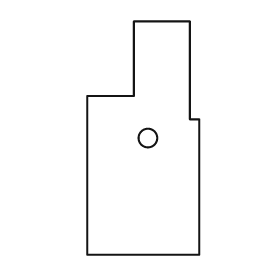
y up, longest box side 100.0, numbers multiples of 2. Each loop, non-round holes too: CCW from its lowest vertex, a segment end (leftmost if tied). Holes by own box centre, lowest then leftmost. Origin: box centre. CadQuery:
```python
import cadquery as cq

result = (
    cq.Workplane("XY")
    .moveTo(-24.0, -50.0)
    .lineTo(24.0, -50.0)
    .lineTo(24.0, 8.0)
    .lineTo(20.0, 8.0)
    .lineTo(20.0, 50.0)
    .lineTo(-4.0, 50.0)
    .lineTo(-4.0, 18.0)
    .lineTo(-24.0, 18.0)
    .close()
    .moveTo(2.0, 0.0)
    .circle(4.0)
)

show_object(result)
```